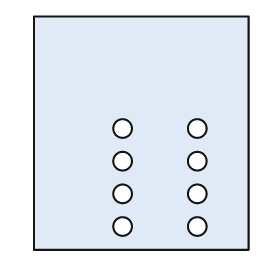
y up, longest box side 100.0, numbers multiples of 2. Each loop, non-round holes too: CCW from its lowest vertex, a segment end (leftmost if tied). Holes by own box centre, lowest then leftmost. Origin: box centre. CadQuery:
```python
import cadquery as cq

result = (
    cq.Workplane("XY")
    .moveTo(-46.0, -50.0)
    .lineTo(46.0, -50.0)
    .lineTo(46.0, 50.0)
    .lineTo(-46.0, 50.0)
    .close()
    .moveTo(-8.0, -40.0)
    .circle(4.0)
    .moveTo(24.0, -40.0)
    .circle(4.0)
    .moveTo(-8.0, -26.0)
    .circle(4.0)
    .moveTo(24.0, -26.0)
    .circle(4.0)
    .moveTo(-8.0, -12.0)
    .circle(4.0)
    .moveTo(24.0, -12.0)
    .circle(4.0)
    .moveTo(-8.0, 2.0)
    .circle(4.0)
    .moveTo(24.0, 2.0)
    .circle(4.0)
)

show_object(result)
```